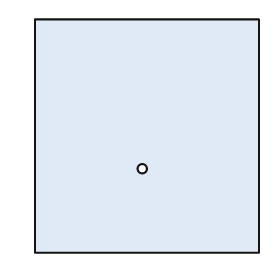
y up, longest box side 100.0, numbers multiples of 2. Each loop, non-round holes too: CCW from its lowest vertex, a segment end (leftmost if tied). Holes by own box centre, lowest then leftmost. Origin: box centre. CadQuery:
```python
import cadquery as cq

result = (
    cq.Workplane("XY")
    .moveTo(-48.0, -50.0)
    .lineTo(48.0, -50.0)
    .lineTo(48.0, 50.0)
    .lineTo(-48.0, 50.0)
    .close()
    .moveTo(-2.0, -14.0)
    .circle(2.0)
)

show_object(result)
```